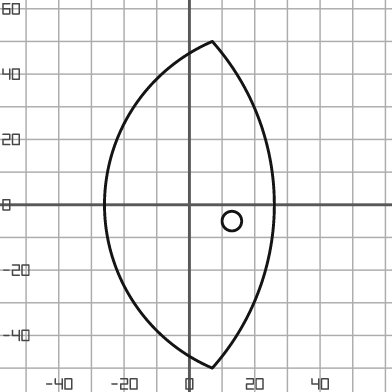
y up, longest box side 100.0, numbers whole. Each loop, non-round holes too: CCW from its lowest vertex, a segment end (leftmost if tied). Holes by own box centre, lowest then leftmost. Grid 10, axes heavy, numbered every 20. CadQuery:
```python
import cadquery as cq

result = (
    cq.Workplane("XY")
    .moveTo(7.0, -50.0)
    .threePointArc((26.0, 0.0), (7.0, 50.0))
    .threePointArc((-26.0, 0.0), (7.0, -50.0))
    .close()
    .moveTo(13.0, -5.0)
    .circle(3.0)
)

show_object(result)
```